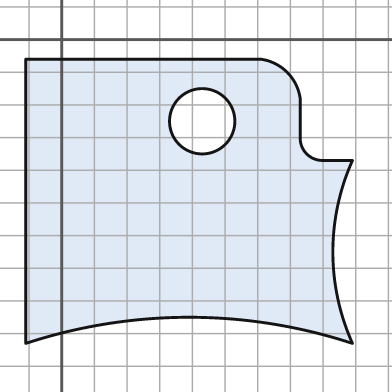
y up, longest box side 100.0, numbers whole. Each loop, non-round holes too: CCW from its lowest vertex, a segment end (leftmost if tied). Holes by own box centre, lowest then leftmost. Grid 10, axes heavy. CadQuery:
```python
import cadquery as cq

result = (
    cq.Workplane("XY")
    .moveTo(-11.0, -93.0)
    .threePointArc((39.0, -85.0), (89.0, -93.0))
    .threePointArc((83.0, -65.0), (89.0, -37.0))
    .lineTo(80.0, -37.0)
    .threePointArc((75.0, -35.0), (73.0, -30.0))
    .lineTo(73.0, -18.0)
    .threePointArc((69.0, -10.0), (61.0, -6.0))
    .lineTo(-11.0, -6.0)
    .close()
    .moveTo(43.0, -25.0)
    .circle(10.0)
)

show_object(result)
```